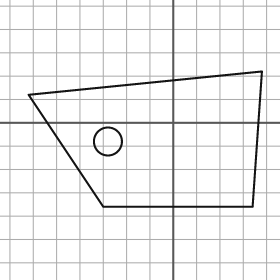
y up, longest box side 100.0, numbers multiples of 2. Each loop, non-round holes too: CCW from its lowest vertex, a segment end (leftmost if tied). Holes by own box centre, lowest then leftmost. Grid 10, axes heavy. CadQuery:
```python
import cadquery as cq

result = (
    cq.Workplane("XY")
    .moveTo(-30.0, -36.0)
    .lineTo(34.0, -36.0)
    .lineTo(38.0, 22.0)
    .lineTo(-62.0, 12.0)
    .close()
    .moveTo(-28.0, -8.0)
    .circle(6.0)
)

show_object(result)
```